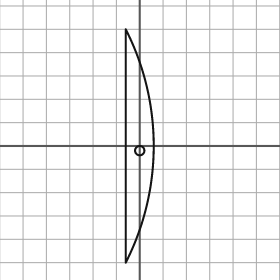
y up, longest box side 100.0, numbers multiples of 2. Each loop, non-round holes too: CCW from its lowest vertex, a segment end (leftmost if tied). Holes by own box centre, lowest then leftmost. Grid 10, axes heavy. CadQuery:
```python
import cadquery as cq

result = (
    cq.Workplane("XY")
    .moveTo(-6.0, -50.0)
    .threePointArc((6.0, 0.0), (-6.0, 50.0))
    .close()
    .moveTo(0.0, -2.0)
    .circle(2.0)
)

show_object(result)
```